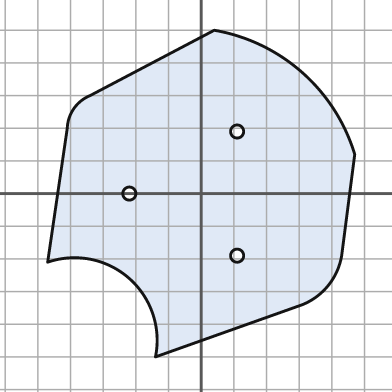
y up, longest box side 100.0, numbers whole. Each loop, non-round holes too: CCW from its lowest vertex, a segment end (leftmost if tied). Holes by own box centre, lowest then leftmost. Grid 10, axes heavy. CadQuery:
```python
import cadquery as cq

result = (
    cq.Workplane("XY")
    .moveTo(-14.0, -50.0)
    .lineTo(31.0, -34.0)
    .threePointArc((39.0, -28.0), (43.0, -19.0))
    .lineTo(47.0, 12.0)
    .threePointArc((31.0, 37.0), (4.0, 50.0))
    .lineTo(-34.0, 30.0)
    .threePointArc((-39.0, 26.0), (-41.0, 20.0))
    .lineTo(-47.0, -21.0)
    .threePointArc((-22.0, -26.0), (-14.0, -50.0))
    .close()
    .moveTo(11.0, -19.0)
    .circle(2.0)
    .moveTo(-22.0, 0.0)
    .circle(2.0)
    .moveTo(11.0, 19.0)
    .circle(2.0)
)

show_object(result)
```